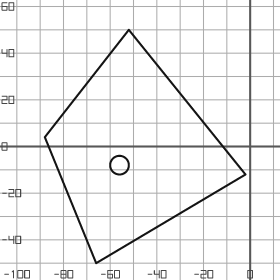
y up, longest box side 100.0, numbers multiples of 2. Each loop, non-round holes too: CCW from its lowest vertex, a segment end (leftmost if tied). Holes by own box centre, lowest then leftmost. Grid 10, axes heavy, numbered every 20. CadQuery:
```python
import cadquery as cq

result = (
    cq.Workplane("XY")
    .moveTo(-66.0, -50.0)
    .lineTo(-2.0, -12.0)
    .lineTo(-52.0, 50.0)
    .lineTo(-88.0, 4.0)
    .close()
    .moveTo(-56.0, -8.0)
    .circle(4.0)
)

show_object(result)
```